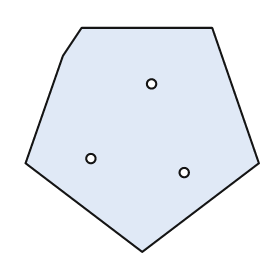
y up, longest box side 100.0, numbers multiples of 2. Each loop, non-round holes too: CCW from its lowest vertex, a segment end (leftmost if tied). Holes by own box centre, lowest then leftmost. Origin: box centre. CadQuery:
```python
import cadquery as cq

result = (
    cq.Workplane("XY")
    .moveTo(0.0, -48.0)
    .lineTo(50.0, -10.0)
    .lineTo(30.0, 48.0)
    .lineTo(-26.0, 48.0)
    .lineTo(-34.0, 36.0)
    .lineTo(-50.0, -10.0)
    .close()
    .moveTo(18.0, -14.0)
    .circle(2.0)
    .moveTo(-22.0, -8.0)
    .circle(2.0)
    .moveTo(4.0, 24.0)
    .circle(2.0)
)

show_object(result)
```